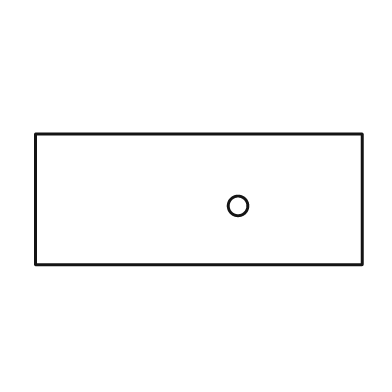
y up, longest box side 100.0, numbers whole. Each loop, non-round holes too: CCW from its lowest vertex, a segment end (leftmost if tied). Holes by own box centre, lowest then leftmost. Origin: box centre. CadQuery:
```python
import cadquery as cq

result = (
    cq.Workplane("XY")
    .moveTo(-50.0, -20.0)
    .lineTo(50.0, -20.0)
    .lineTo(50.0, 20.0)
    .lineTo(-50.0, 20.0)
    .close()
    .moveTo(12.0, -2.0)
    .circle(3.0)
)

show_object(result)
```